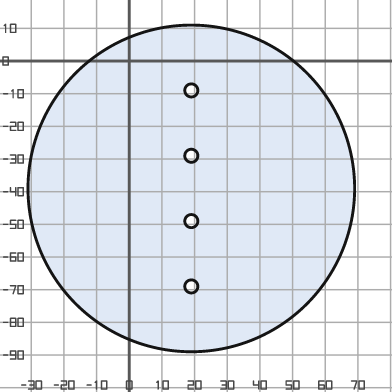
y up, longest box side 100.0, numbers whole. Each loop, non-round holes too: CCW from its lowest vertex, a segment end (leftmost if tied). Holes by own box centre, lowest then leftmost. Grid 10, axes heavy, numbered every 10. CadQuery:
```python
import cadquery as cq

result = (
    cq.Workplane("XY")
    .moveTo(19.0, -39.0)
    .circle(50.0)
    .moveTo(19.0, -69.0)
    .circle(2.0)
    .moveTo(19.0, -49.0)
    .circle(2.0)
    .moveTo(19.0, -29.0)
    .circle(2.0)
    .moveTo(19.0, -9.0)
    .circle(2.0)
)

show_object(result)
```